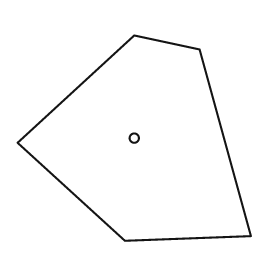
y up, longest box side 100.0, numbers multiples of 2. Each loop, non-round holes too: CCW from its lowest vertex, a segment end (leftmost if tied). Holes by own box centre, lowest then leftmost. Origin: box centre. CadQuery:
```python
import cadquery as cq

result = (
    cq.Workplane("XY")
    .moveTo(-4.0, -44.0)
    .lineTo(50.0, -42.0)
    .lineTo(28.0, 38.0)
    .lineTo(0.0, 44.0)
    .lineTo(-50.0, -2.0)
    .close()
    .moveTo(0.0, 0.0)
    .circle(2.0)
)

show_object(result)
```